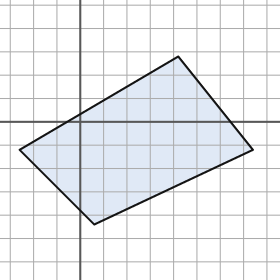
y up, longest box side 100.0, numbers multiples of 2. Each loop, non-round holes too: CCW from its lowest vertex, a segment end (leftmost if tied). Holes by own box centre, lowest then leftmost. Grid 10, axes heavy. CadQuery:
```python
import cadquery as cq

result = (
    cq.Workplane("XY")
    .moveTo(6.0, -44.0)
    .lineTo(74.0, -12.0)
    .lineTo(42.0, 28.0)
    .lineTo(-26.0, -12.0)
    .close()
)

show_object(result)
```